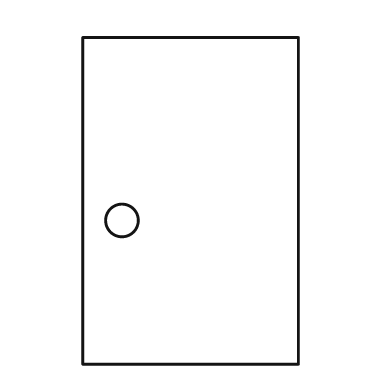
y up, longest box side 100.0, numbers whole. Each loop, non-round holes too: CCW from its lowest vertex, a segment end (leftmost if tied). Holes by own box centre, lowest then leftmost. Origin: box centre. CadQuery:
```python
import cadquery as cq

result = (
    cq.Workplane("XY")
    .moveTo(-33.0, -50.0)
    .lineTo(33.0, -50.0)
    .lineTo(33.0, 50.0)
    .lineTo(-33.0, 50.0)
    .close()
    .moveTo(-21.0, -6.0)
    .circle(5.0)
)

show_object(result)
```